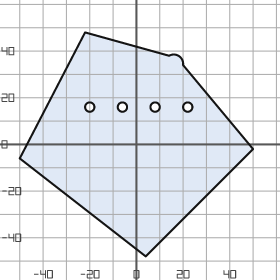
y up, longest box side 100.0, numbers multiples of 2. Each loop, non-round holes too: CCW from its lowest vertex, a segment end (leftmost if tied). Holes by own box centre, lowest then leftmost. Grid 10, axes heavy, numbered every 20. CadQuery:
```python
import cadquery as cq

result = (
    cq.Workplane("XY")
    .moveTo(4.0, -48.0)
    .lineTo(50.0, -2.0)
    .lineTo(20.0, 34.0)
    .threePointArc((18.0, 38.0), (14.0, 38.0))
    .lineTo(-22.0, 48.0)
    .lineTo(-50.0, -6.0)
    .close()
    .moveTo(-20.0, 16.0)
    .circle(2.0)
    .moveTo(-6.0, 16.0)
    .circle(2.0)
    .moveTo(8.0, 16.0)
    .circle(2.0)
    .moveTo(22.0, 16.0)
    .circle(2.0)
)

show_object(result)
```